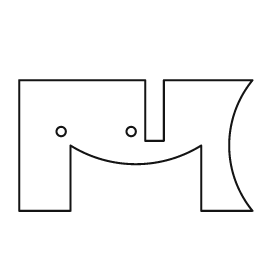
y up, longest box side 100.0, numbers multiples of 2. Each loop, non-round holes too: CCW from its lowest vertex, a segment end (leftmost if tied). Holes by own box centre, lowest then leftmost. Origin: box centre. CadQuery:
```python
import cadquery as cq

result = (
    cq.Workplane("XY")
    .moveTo(-50.0, -28.0)
    .lineTo(-28.0, -28.0)
    .lineTo(-28.0, 0.0)
    .threePointArc((0.0, -8.0), (28.0, 0.0))
    .lineTo(28.0, -28.0)
    .lineTo(50.0, -28.0)
    .threePointArc((40.0, 0.0), (50.0, 28.0))
    .lineTo(12.0, 28.0)
    .lineTo(12.0, 2.0)
    .lineTo(4.0, 2.0)
    .lineTo(4.0, 28.0)
    .lineTo(-50.0, 28.0)
    .close()
    .moveTo(-32.0, 6.0)
    .circle(2.0)
    .moveTo(-2.0, 6.0)
    .circle(2.0)
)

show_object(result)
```